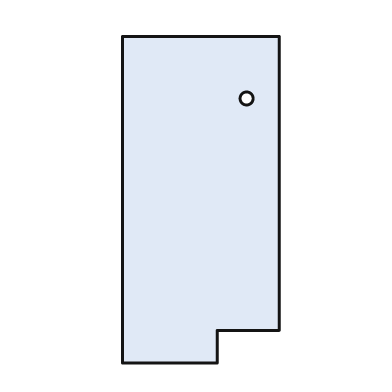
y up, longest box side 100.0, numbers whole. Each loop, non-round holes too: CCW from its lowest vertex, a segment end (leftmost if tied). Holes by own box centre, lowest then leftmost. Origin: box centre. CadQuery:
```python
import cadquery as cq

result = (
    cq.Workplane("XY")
    .moveTo(-24.0, -50.0)
    .lineTo(5.0, -50.0)
    .lineTo(5.0, -40.0)
    .lineTo(24.0, -40.0)
    .lineTo(24.0, 50.0)
    .lineTo(-24.0, 50.0)
    .close()
    .moveTo(14.0, 31.0)
    .circle(2.0)
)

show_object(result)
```